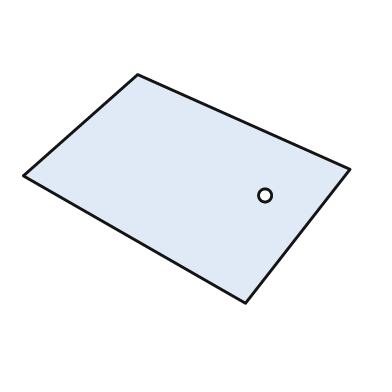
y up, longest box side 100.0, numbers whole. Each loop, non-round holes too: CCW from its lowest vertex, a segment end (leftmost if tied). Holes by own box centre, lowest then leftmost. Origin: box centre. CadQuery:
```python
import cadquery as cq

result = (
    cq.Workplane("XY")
    .moveTo(18.0, -35.0)
    .lineTo(50.0, 6.0)
    .lineTo(-15.0, 35.0)
    .lineTo(-50.0, 4.0)
    .close()
    .moveTo(24.0, -2.0)
    .circle(2.0)
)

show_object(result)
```